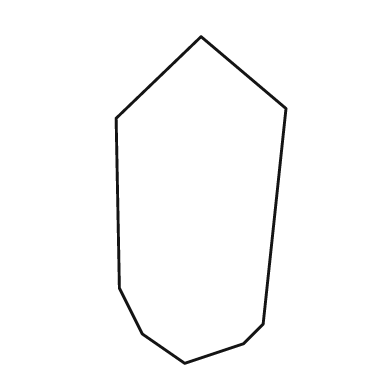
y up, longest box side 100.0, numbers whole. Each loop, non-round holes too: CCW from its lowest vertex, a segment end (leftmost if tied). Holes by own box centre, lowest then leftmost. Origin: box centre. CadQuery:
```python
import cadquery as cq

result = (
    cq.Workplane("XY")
    .moveTo(-5.0, -50.0)
    .lineTo(13.0, -44.0)
    .lineTo(19.0, -38.0)
    .lineTo(26.0, 28.0)
    .lineTo(0.0, 50.0)
    .lineTo(-26.0, 25.0)
    .lineTo(-25.0, -27.0)
    .lineTo(-18.0, -41.0)
    .close()
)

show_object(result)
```